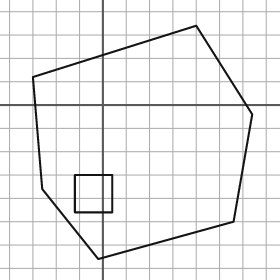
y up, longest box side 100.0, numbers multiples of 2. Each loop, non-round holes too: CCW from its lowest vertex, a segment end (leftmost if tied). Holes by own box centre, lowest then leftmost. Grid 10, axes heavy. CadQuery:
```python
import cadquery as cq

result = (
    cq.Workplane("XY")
    .moveTo(-2.0, -66.0)
    .lineTo(56.0, -50.0)
    .lineTo(64.0, -4.0)
    .lineTo(40.0, 34.0)
    .lineTo(-30.0, 12.0)
    .lineTo(-26.0, -36.0)
    .close()
    .moveTo(-12.0, -46.0)
    .lineTo(4.0, -46.0)
    .lineTo(4.0, -30.0)
    .lineTo(-12.0, -30.0)
    .close()
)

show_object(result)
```